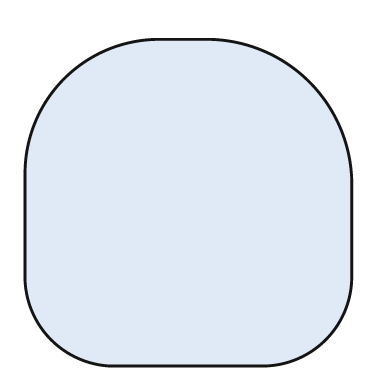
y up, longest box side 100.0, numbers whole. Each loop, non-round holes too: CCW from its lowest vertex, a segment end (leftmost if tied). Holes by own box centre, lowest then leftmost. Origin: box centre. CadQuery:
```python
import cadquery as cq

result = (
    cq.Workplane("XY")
    .moveTo(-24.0, -50.0)
    .lineTo(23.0, -50.0)
    .threePointArc((42.0, -42.0), (50.0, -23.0))
    .lineTo(50.0, 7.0)
    .threePointArc((37.0, 37.0), (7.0, 50.0))
    .lineTo(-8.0, 50.0)
    .threePointArc((-38.0, 38.0), (-50.0, 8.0))
    .lineTo(-50.0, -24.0)
    .threePointArc((-42.0, -42.0), (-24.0, -50.0))
    .close()
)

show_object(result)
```